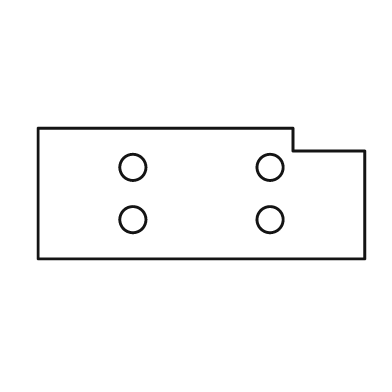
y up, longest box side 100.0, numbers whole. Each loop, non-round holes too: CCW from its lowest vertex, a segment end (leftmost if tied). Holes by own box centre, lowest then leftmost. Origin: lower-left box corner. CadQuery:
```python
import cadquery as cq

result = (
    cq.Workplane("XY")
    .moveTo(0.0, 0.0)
    .lineTo(100.0, 0.0)
    .lineTo(100.0, 33.0)
    .lineTo(78.0, 33.0)
    .lineTo(78.0, 40.0)
    .lineTo(0.0, 40.0)
    .close()
    .moveTo(29.0, 12.0)
    .circle(4.0)
    .moveTo(71.0, 12.0)
    .circle(4.0)
    .moveTo(29.0, 28.0)
    .circle(4.0)
    .moveTo(71.0, 28.0)
    .circle(4.0)
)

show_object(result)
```